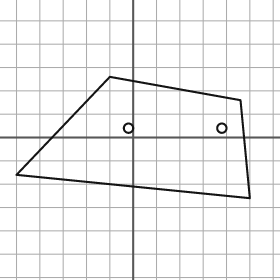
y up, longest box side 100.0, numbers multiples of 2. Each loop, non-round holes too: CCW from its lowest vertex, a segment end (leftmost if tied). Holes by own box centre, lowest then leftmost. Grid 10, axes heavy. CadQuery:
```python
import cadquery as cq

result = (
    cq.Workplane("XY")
    .moveTo(50.0, -26.0)
    .lineTo(46.0, 16.0)
    .lineTo(-10.0, 26.0)
    .lineTo(-50.0, -16.0)
    .close()
    .moveTo(-2.0, 4.0)
    .circle(2.0)
    .moveTo(38.0, 4.0)
    .circle(2.0)
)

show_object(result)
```